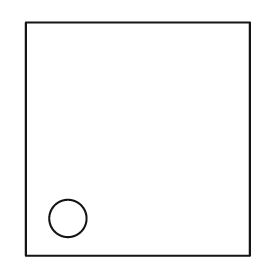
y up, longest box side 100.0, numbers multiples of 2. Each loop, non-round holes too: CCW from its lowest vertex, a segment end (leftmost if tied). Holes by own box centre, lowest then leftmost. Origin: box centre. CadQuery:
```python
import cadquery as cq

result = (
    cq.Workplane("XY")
    .moveTo(-48.0, -50.0)
    .lineTo(48.0, -50.0)
    .lineTo(48.0, 50.0)
    .lineTo(-48.0, 50.0)
    .close()
    .moveTo(-30.0, -34.0)
    .circle(8.0)
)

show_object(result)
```